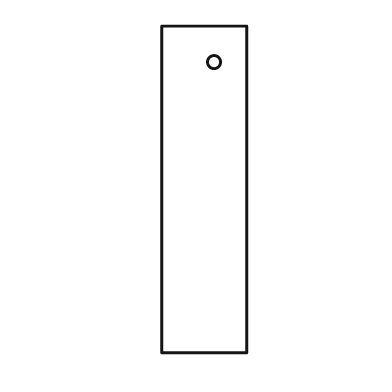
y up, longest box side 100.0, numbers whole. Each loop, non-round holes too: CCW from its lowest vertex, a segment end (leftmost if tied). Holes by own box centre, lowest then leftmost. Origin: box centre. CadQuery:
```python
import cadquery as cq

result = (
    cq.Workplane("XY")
    .moveTo(-13.0, -50.0)
    .lineTo(13.0, -50.0)
    .lineTo(13.0, 50.0)
    .lineTo(-13.0, 50.0)
    .close()
    .moveTo(3.0, 39.0)
    .circle(2.0)
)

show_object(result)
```